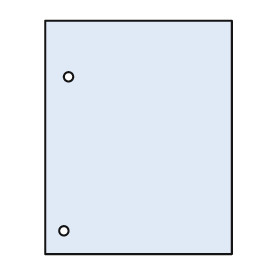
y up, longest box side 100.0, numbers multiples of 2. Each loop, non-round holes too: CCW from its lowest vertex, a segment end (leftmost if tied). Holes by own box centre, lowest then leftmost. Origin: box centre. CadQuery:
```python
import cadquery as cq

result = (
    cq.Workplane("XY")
    .moveTo(-40.0, -50.0)
    .lineTo(40.0, -50.0)
    .lineTo(40.0, 50.0)
    .lineTo(-40.0, 50.0)
    .close()
    .moveTo(-32.0, -40.0)
    .circle(2.0)
    .moveTo(-30.0, 26.0)
    .circle(2.0)
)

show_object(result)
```